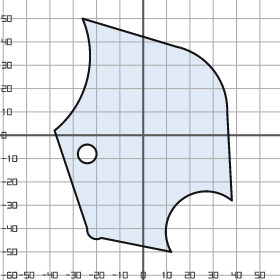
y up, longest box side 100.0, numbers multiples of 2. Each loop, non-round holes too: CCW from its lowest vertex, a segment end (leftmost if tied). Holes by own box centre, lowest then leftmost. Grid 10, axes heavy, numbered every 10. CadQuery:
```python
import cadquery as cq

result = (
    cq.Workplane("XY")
    .moveTo(12.0, -50.0)
    .threePointArc((16.0, -28.0), (38.0, -28.0))
    .lineTo(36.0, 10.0)
    .threePointArc((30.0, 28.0), (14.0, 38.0))
    .lineTo(-26.0, 50.0)
    .threePointArc((-24.0, 24.0), (-38.0, 2.0))
    .lineTo(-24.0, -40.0)
    .threePointArc((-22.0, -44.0), (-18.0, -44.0))
    .close()
    .moveTo(-24.0, -8.0)
    .circle(4.0)
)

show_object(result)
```